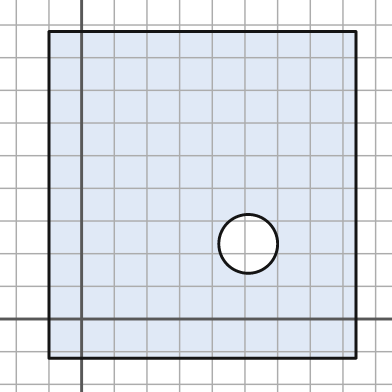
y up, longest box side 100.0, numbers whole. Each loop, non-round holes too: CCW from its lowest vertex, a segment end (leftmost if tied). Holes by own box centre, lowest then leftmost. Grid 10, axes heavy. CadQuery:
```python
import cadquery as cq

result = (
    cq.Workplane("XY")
    .moveTo(-10.0, -12.0)
    .lineTo(84.0, -12.0)
    .lineTo(84.0, 88.0)
    .lineTo(-10.0, 88.0)
    .close()
    .moveTo(51.0, 23.0)
    .circle(9.0)
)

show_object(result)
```